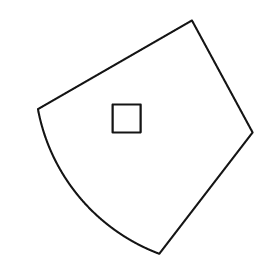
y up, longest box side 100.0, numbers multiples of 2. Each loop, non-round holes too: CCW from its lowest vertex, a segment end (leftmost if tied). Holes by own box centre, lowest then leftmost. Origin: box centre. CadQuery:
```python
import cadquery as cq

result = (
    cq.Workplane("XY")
    .moveTo(6.0, -50.0)
    .lineTo(46.0, 2.0)
    .lineTo(20.0, 50.0)
    .lineTo(-46.0, 12.0)
    .threePointArc((-28.0, -26.0), (6.0, -50.0))
    .close()
    .moveTo(-14.0, 2.0)
    .lineTo(-2.0, 2.0)
    .lineTo(-2.0, 14.0)
    .lineTo(-14.0, 14.0)
    .close()
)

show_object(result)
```